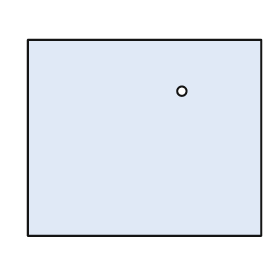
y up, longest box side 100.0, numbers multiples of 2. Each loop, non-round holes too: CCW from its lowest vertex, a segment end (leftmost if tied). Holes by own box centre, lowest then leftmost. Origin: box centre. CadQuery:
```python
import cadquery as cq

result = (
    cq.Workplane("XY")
    .moveTo(-50.0, -42.0)
    .lineTo(50.0, -42.0)
    .lineTo(50.0, 42.0)
    .lineTo(-50.0, 42.0)
    .close()
    .moveTo(16.0, 20.0)
    .circle(2.0)
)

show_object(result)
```